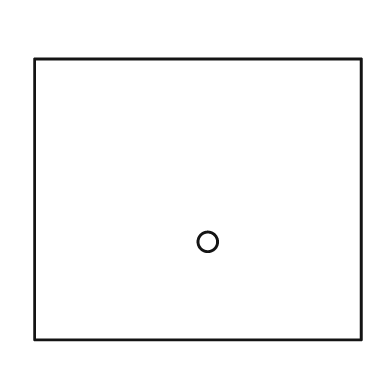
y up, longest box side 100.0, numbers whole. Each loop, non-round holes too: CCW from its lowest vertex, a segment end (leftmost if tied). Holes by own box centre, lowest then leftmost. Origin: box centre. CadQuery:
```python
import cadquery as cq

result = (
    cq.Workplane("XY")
    .moveTo(-50.0, -43.0)
    .lineTo(50.0, -43.0)
    .lineTo(50.0, 43.0)
    .lineTo(-50.0, 43.0)
    .close()
    .moveTo(3.0, -13.0)
    .circle(3.0)
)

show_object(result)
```